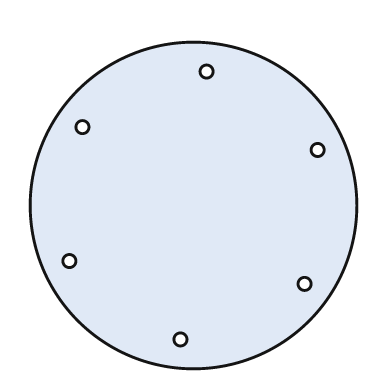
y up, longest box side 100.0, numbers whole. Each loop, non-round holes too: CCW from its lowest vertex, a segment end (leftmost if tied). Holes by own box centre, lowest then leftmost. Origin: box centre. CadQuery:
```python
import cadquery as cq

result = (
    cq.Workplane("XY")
    .moveTo(0.0, 0.0)
    .circle(50.0)
    .moveTo(-4.0, -41.0)
    .circle(2.0)
    .moveTo(34.0, -24.0)
    .circle(2.0)
    .moveTo(-38.0, -17.0)
    .circle(2.0)
    .moveTo(38.0, 17.0)
    .circle(2.0)
    .moveTo(-34.0, 24.0)
    .circle(2.0)
    .moveTo(4.0, 41.0)
    .circle(2.0)
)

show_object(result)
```